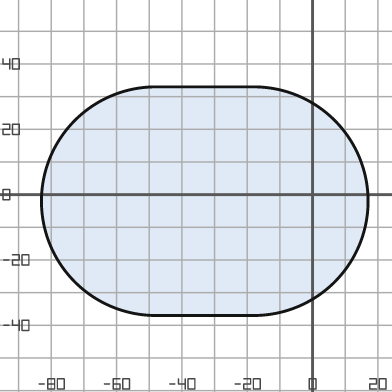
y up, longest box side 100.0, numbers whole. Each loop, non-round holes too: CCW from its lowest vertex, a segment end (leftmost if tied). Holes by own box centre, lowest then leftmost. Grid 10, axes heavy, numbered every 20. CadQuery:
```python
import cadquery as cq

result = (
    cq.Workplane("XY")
    .moveTo(-48.0, -37.0)
    .lineTo(-18.0, -37.0)
    .threePointArc((17.0, -2.0), (-18.0, 33.0))
    .lineTo(-48.0, 33.0)
    .threePointArc((-83.0, -2.0), (-48.0, -37.0))
    .close()
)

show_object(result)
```